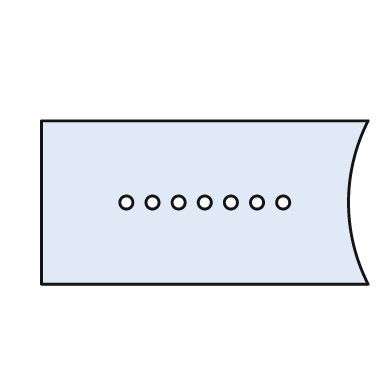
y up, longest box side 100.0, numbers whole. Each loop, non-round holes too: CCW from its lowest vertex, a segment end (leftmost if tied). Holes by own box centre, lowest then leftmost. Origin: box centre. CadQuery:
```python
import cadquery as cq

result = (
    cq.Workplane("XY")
    .moveTo(-50.0, -25.0)
    .lineTo(50.0, -25.0)
    .threePointArc((44.0, 0.0), (50.0, 25.0))
    .lineTo(-50.0, 25.0)
    .close()
    .moveTo(-24.0, 0.0)
    .circle(2.0)
    .moveTo(-16.0, 0.0)
    .circle(2.0)
    .moveTo(-8.0, 0.0)
    .circle(2.0)
    .moveTo(0.0, 0.0)
    .circle(2.0)
    .moveTo(8.0, 0.0)
    .circle(2.0)
    .moveTo(16.0, 0.0)
    .circle(2.0)
    .moveTo(24.0, 0.0)
    .circle(2.0)
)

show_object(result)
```